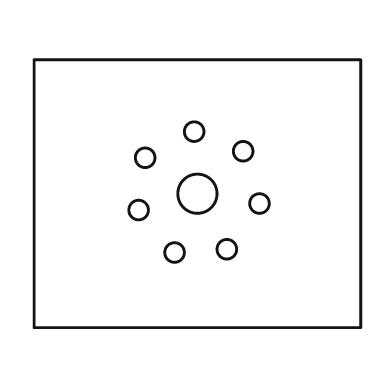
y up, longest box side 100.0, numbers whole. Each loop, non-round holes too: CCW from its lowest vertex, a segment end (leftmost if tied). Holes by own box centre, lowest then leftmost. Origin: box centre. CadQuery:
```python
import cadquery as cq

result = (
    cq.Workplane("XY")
    .moveTo(-50.0, -41.0)
    .lineTo(50.0, -41.0)
    .lineTo(50.0, 41.0)
    .lineTo(-50.0, 41.0)
    .close()
    .moveTo(-7.0, -18.0)
    .circle(3.0)
    .moveTo(9.0, -17.0)
    .circle(3.0)
    .moveTo(-18.0, -5.0)
    .circle(3.0)
    .moveTo(19.0, -3.0)
    .circle(3.0)
    .moveTo(0.0, 0.0)
    .circle(6.0)
    .moveTo(-16.0, 11.0)
    .circle(3.0)
    .moveTo(14.0, 13.0)
    .circle(3.0)
    .moveTo(-1.0, 19.0)
    .circle(3.0)
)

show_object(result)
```